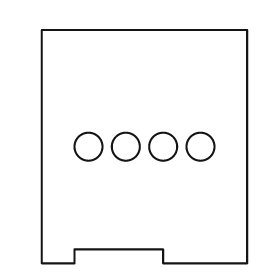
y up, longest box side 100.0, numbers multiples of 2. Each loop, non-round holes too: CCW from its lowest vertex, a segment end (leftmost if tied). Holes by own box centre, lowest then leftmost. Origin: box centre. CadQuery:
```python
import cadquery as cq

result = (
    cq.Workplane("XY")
    .moveTo(-44.0, -50.0)
    .lineTo(-30.0, -50.0)
    .lineTo(-30.0, -44.0)
    .lineTo(8.0, -44.0)
    .lineTo(8.0, -50.0)
    .lineTo(44.0, -50.0)
    .lineTo(44.0, 50.0)
    .lineTo(-44.0, 50.0)
    .close()
    .moveTo(-24.0, 0.0)
    .circle(6.0)
    .moveTo(-8.0, 0.0)
    .circle(6.0)
    .moveTo(8.0, 0.0)
    .circle(6.0)
    .moveTo(24.0, 0.0)
    .circle(6.0)
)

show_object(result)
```